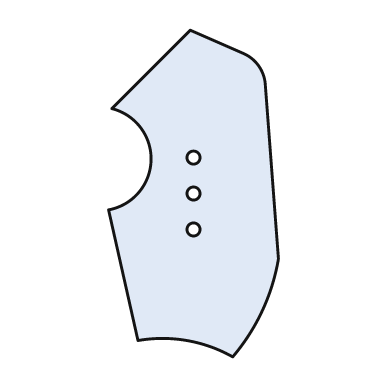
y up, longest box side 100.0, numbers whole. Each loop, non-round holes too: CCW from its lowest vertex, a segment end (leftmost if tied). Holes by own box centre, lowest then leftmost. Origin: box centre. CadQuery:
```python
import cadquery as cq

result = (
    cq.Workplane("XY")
    .moveTo(12.0, -50.0)
    .threePointArc((21.0, -36.0), (26.0, -20.0))
    .lineTo(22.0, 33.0)
    .threePointArc((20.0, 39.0), (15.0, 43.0))
    .lineTo(-1.0, 50.0)
    .lineTo(-25.0, 26.0)
    .threePointArc((-13.0, 10.0), (-26.0, -5.0))
    .lineTo(-17.0, -45.0)
    .threePointArc((-2.0, -45.0), (12.0, -50.0))
    .close()
    .moveTo(0.0, -11.0)
    .circle(2.0)
    .moveTo(0.0, 0.0)
    .circle(2.0)
    .moveTo(0.0, 11.0)
    .circle(2.0)
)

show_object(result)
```